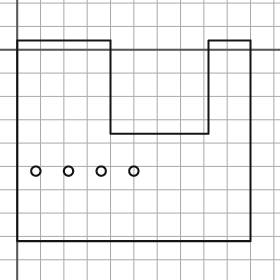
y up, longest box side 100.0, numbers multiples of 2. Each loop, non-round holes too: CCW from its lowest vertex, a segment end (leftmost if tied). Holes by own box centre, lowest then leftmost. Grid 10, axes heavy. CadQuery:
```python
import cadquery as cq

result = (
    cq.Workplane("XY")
    .moveTo(0.0, -82.0)
    .lineTo(100.0, -82.0)
    .lineTo(100.0, 4.0)
    .lineTo(82.0, 4.0)
    .lineTo(82.0, -36.0)
    .lineTo(40.0, -36.0)
    .lineTo(40.0, 4.0)
    .lineTo(0.0, 4.0)
    .close()
    .moveTo(8.0, -52.0)
    .circle(2.0)
    .moveTo(22.0, -52.0)
    .circle(2.0)
    .moveTo(36.0, -52.0)
    .circle(2.0)
    .moveTo(50.0, -52.0)
    .circle(2.0)
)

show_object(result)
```